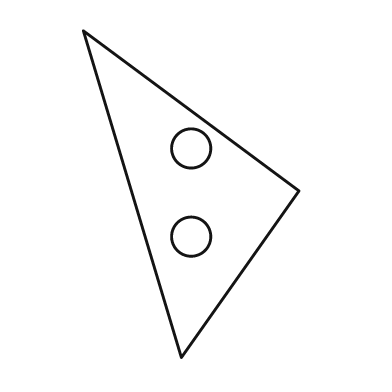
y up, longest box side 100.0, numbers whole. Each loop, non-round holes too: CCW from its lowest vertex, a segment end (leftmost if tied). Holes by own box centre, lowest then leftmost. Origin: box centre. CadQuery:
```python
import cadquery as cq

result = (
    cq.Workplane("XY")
    .moveTo(-3.0, -50.0)
    .lineTo(33.0, 1.0)
    .lineTo(-33.0, 50.0)
    .close()
    .moveTo(0.0, -13.0)
    .circle(6.0)
    .moveTo(0.0, 14.0)
    .circle(6.0)
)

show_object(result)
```